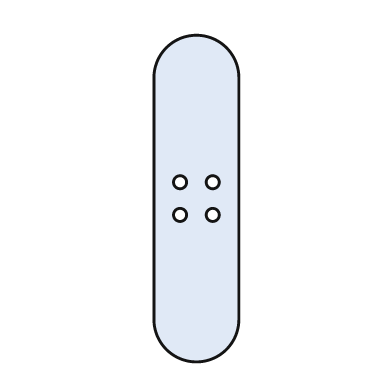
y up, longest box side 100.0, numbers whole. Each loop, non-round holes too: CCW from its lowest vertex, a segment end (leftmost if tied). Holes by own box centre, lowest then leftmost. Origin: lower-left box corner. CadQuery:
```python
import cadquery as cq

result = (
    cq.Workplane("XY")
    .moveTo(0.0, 13.0)
    .threePointArc((13.0, 0.0), (26.0, 13.0))
    .lineTo(26.0, 87.0)
    .threePointArc((13.0, 100.0), (0.0, 87.0))
    .close()
    .moveTo(8.0, 45.0)
    .circle(2.0)
    .moveTo(18.0, 45.0)
    .circle(2.0)
    .moveTo(8.0, 55.0)
    .circle(2.0)
    .moveTo(18.0, 55.0)
    .circle(2.0)
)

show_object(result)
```